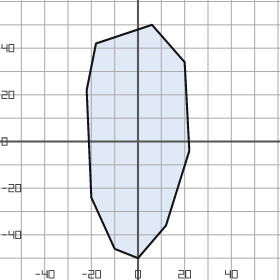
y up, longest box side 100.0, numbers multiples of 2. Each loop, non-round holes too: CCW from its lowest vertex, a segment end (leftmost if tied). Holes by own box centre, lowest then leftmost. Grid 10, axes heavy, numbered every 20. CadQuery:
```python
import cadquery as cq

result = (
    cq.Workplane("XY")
    .moveTo(0.0, -50.0)
    .lineTo(12.0, -36.0)
    .lineTo(22.0, -4.0)
    .lineTo(20.0, 34.0)
    .lineTo(6.0, 50.0)
    .lineTo(-18.0, 42.0)
    .lineTo(-22.0, 22.0)
    .lineTo(-20.0, -24.0)
    .lineTo(-10.0, -46.0)
    .close()
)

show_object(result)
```